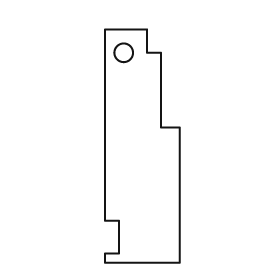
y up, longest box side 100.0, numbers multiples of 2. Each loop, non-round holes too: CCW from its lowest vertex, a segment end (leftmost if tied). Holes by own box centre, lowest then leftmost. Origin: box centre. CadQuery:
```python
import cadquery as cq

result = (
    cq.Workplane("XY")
    .moveTo(-16.0, -50.0)
    .lineTo(16.0, -50.0)
    .lineTo(16.0, 8.0)
    .lineTo(8.0, 8.0)
    .lineTo(8.0, 40.0)
    .lineTo(2.0, 40.0)
    .lineTo(2.0, 50.0)
    .lineTo(-16.0, 50.0)
    .lineTo(-16.0, -32.0)
    .lineTo(-10.0, -32.0)
    .lineTo(-10.0, -46.0)
    .lineTo(-16.0, -46.0)
    .close()
    .moveTo(-8.0, 40.0)
    .circle(4.0)
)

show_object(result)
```